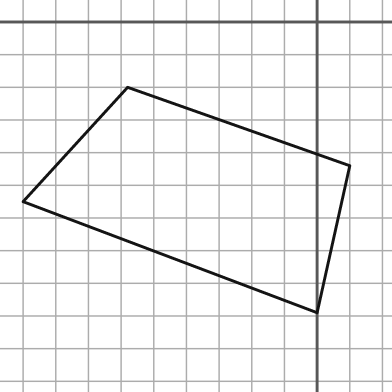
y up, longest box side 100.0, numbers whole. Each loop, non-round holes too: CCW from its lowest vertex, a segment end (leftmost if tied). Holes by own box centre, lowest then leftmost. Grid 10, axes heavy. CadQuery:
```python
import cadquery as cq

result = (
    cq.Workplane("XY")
    .moveTo(0.0, -89.0)
    .lineTo(10.0, -44.0)
    .lineTo(-58.0, -20.0)
    .lineTo(-90.0, -55.0)
    .close()
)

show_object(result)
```